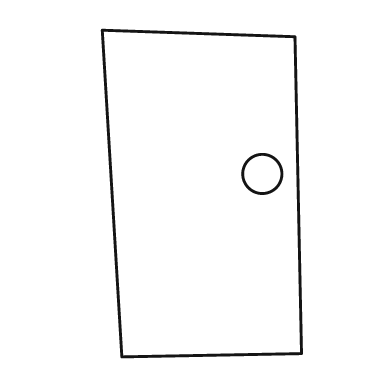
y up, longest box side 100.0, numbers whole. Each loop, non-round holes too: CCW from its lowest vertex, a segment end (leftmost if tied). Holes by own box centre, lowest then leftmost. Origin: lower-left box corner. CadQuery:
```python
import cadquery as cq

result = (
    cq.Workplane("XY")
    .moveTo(6.0, 0.0)
    .lineTo(61.0, 1.0)
    .lineTo(59.0, 98.0)
    .lineTo(0.0, 100.0)
    .close()
    .moveTo(49.0, 56.0)
    .circle(6.0)
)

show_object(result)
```